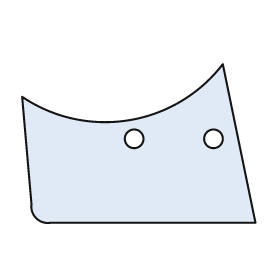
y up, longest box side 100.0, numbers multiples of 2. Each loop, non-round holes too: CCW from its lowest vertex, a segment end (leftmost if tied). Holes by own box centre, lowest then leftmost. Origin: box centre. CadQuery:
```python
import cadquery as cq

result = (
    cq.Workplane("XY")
    .moveTo(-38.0, -34.0)
    .lineTo(50.0, -34.0)
    .lineTo(36.0, 34.0)
    .threePointArc((-4.0, 10.0), (-50.0, 20.0))
    .lineTo(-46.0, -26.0)
    .threePointArc((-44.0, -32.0), (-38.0, -34.0))
    .close()
    .moveTo(-2.0, 2.0)
    .circle(4.0)
    .moveTo(32.0, 2.0)
    .circle(4.0)
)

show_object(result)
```